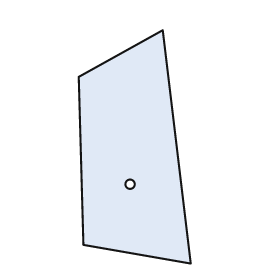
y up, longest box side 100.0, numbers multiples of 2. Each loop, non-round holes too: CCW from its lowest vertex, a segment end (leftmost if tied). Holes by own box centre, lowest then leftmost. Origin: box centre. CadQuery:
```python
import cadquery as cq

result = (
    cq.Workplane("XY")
    .moveTo(24.0, -50.0)
    .lineTo(12.0, 50.0)
    .lineTo(-24.0, 30.0)
    .lineTo(-22.0, -42.0)
    .close()
    .moveTo(-2.0, -16.0)
    .circle(2.0)
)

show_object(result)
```